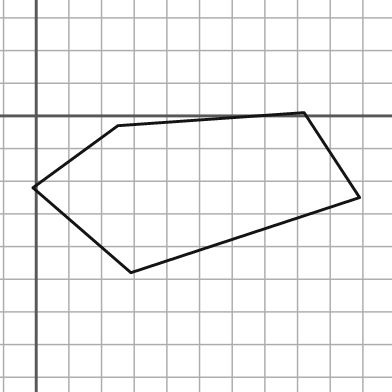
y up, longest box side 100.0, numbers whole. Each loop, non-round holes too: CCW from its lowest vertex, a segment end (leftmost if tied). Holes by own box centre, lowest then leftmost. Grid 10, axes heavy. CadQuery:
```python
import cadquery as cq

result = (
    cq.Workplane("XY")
    .moveTo(29.0, -48.0)
    .lineTo(99.0, -25.0)
    .lineTo(82.0, 1.0)
    .lineTo(25.0, -3.0)
    .lineTo(-1.0, -22.0)
    .close()
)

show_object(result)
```